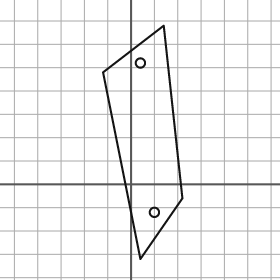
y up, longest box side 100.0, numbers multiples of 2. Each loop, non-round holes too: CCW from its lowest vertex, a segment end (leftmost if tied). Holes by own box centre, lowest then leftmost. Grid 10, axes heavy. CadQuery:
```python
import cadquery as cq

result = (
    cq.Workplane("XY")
    .moveTo(4.0, -32.0)
    .lineTo(22.0, -6.0)
    .lineTo(14.0, 68.0)
    .lineTo(-12.0, 48.0)
    .close()
    .moveTo(10.0, -12.0)
    .circle(2.0)
    .moveTo(4.0, 52.0)
    .circle(2.0)
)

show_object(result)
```